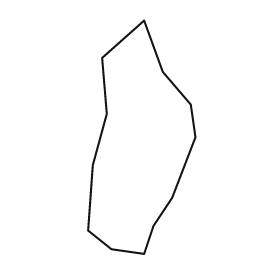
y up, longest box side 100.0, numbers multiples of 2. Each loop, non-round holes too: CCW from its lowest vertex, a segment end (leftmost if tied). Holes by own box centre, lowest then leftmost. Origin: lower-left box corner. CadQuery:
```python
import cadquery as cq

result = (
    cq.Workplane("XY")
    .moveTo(24.0, 0.0)
    .lineTo(28.0, 12.0)
    .lineTo(36.0, 24.0)
    .lineTo(46.0, 50.0)
    .lineTo(44.0, 64.0)
    .lineTo(32.0, 78.0)
    .lineTo(24.0, 100.0)
    .lineTo(6.0, 84.0)
    .lineTo(8.0, 60.0)
    .lineTo(2.0, 38.0)
    .lineTo(0.0, 10.0)
    .lineTo(10.0, 2.0)
    .close()
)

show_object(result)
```